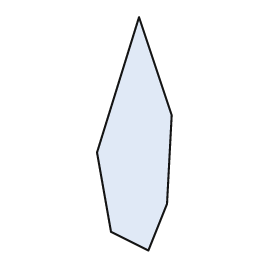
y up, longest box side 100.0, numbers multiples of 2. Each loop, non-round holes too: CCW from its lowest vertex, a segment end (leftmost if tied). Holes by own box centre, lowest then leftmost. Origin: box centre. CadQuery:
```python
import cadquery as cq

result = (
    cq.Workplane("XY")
    .moveTo(6.0, -50.0)
    .lineTo(14.0, -30.0)
    .lineTo(16.0, 8.0)
    .lineTo(2.0, 50.0)
    .lineTo(-16.0, -8.0)
    .lineTo(-10.0, -42.0)
    .close()
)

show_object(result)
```